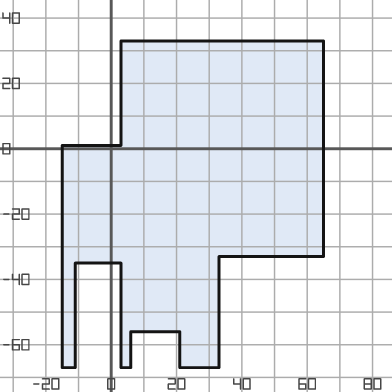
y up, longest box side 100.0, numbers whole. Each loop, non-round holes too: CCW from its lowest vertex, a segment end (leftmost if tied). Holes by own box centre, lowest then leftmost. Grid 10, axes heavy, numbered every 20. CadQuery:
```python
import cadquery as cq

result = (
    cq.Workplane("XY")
    .moveTo(-15.0, -67.0)
    .lineTo(-11.0, -67.0)
    .lineTo(-11.0, -35.0)
    .lineTo(3.0, -35.0)
    .lineTo(3.0, -67.0)
    .lineTo(6.0, -67.0)
    .lineTo(6.0, -56.0)
    .lineTo(21.0, -56.0)
    .lineTo(21.0, -67.0)
    .lineTo(33.0, -67.0)
    .lineTo(33.0, -33.0)
    .lineTo(65.0, -33.0)
    .lineTo(65.0, 33.0)
    .lineTo(3.0, 33.0)
    .lineTo(3.0, 1.0)
    .lineTo(-15.0, 1.0)
    .close()
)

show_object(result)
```